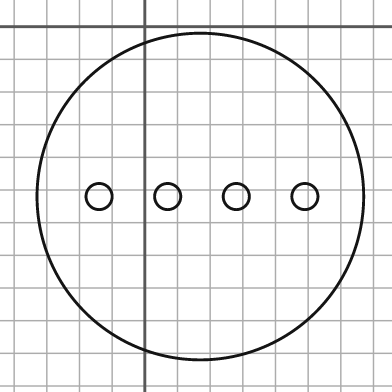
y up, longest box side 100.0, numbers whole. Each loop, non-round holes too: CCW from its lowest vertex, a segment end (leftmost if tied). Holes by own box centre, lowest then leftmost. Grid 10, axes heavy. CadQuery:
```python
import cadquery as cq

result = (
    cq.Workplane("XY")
    .moveTo(17.0, -52.0)
    .circle(50.0)
    .moveTo(-14.0, -52.0)
    .circle(4.0)
    .moveTo(7.0, -52.0)
    .circle(4.0)
    .moveTo(28.0, -52.0)
    .circle(4.0)
    .moveTo(49.0, -52.0)
    .circle(4.0)
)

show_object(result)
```